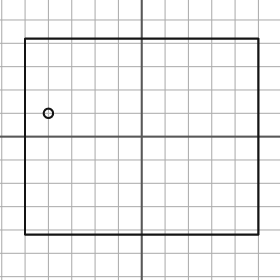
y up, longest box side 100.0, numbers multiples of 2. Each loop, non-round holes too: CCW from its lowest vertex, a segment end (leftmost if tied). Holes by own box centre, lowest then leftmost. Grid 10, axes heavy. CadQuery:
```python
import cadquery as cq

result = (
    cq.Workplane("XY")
    .moveTo(-50.0, -42.0)
    .lineTo(50.0, -42.0)
    .lineTo(50.0, 42.0)
    .lineTo(-50.0, 42.0)
    .close()
    .moveTo(-40.0, 10.0)
    .circle(2.0)
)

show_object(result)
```